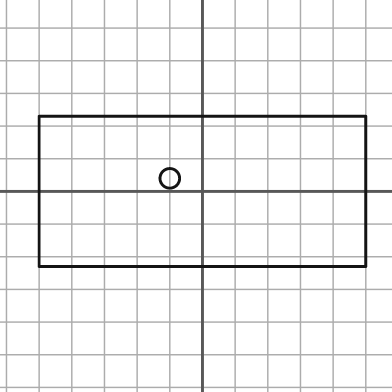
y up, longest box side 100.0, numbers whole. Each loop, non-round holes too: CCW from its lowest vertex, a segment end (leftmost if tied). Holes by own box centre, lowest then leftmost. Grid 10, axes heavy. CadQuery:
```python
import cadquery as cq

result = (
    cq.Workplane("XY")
    .moveTo(-50.0, -23.0)
    .lineTo(50.0, -23.0)
    .lineTo(50.0, 23.0)
    .lineTo(-50.0, 23.0)
    .close()
    .moveTo(-10.0, 4.0)
    .circle(3.0)
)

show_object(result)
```